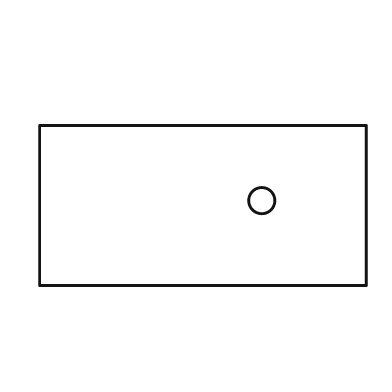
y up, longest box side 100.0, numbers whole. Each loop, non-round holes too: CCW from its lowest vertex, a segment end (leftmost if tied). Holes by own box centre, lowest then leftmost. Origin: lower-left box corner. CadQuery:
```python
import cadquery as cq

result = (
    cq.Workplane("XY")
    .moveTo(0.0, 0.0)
    .lineTo(100.0, 0.0)
    .lineTo(100.0, 49.0)
    .lineTo(0.0, 49.0)
    .close()
    .moveTo(68.0, 26.0)
    .circle(4.0)
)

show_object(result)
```